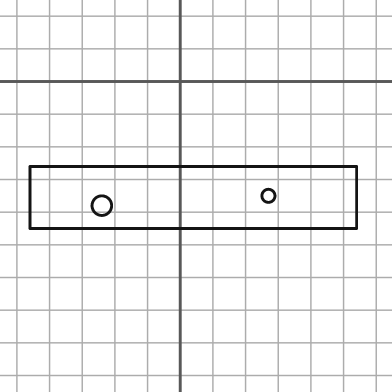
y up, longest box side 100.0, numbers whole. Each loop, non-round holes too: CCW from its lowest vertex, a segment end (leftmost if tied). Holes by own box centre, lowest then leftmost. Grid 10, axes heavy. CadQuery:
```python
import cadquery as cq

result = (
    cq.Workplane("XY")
    .moveTo(-46.0, -45.0)
    .lineTo(54.0, -45.0)
    .lineTo(54.0, -26.0)
    .lineTo(-46.0, -26.0)
    .close()
    .moveTo(-24.0, -38.0)
    .circle(3.0)
    .moveTo(27.0, -35.0)
    .circle(2.0)
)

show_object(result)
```